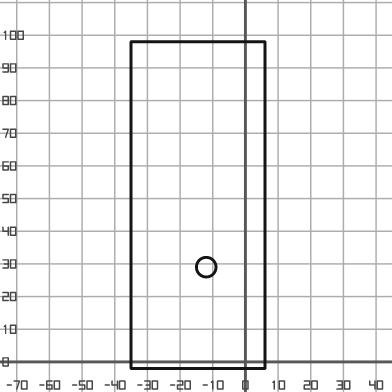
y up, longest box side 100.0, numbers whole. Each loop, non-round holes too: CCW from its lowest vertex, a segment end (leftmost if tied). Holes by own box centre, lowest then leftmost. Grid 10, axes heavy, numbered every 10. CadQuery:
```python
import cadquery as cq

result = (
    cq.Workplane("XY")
    .moveTo(-35.0, -2.0)
    .lineTo(6.0, -2.0)
    .lineTo(6.0, 98.0)
    .lineTo(-35.0, 98.0)
    .close()
    .moveTo(-12.0, 29.0)
    .circle(3.0)
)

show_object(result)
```